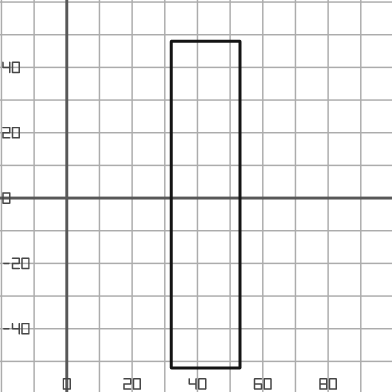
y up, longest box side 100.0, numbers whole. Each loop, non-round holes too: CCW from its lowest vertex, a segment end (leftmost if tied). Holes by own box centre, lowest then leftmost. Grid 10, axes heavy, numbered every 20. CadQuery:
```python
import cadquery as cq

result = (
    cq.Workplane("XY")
    .moveTo(32.0, -52.0)
    .lineTo(53.0, -52.0)
    .lineTo(53.0, 48.0)
    .lineTo(32.0, 48.0)
    .close()
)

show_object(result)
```